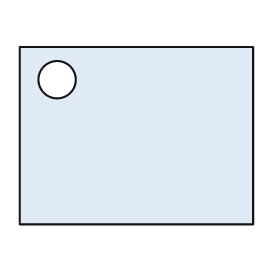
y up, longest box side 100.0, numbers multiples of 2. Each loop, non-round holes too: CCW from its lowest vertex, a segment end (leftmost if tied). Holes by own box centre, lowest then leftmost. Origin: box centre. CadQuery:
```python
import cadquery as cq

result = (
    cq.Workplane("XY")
    .moveTo(-50.0, -38.0)
    .lineTo(50.0, -38.0)
    .lineTo(50.0, 38.0)
    .lineTo(-50.0, 38.0)
    .close()
    .moveTo(-34.0, 24.0)
    .circle(8.0)
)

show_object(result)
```